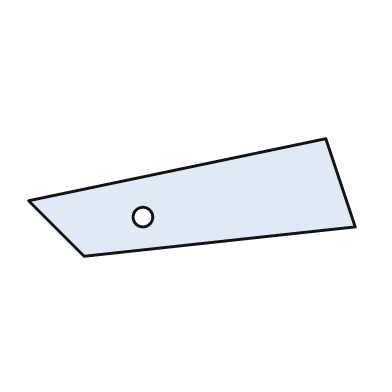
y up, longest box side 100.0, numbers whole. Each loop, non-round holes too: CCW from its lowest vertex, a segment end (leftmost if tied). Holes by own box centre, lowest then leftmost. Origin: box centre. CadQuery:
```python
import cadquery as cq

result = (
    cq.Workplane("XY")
    .moveTo(-33.0, -18.0)
    .lineTo(50.0, -9.0)
    .lineTo(41.0, 18.0)
    .lineTo(-50.0, -1.0)
    .close()
    .moveTo(-15.0, -6.0)
    .circle(3.0)
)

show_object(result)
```